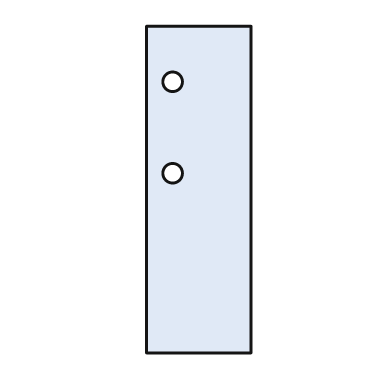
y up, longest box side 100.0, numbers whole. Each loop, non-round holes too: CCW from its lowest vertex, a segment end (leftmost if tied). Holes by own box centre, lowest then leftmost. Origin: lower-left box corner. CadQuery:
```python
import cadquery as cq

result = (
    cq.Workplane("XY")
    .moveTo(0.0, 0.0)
    .lineTo(32.0, 0.0)
    .lineTo(32.0, 100.0)
    .lineTo(0.0, 100.0)
    .close()
    .moveTo(8.0, 55.0)
    .circle(3.0)
    .moveTo(8.0, 83.0)
    .circle(3.0)
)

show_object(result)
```